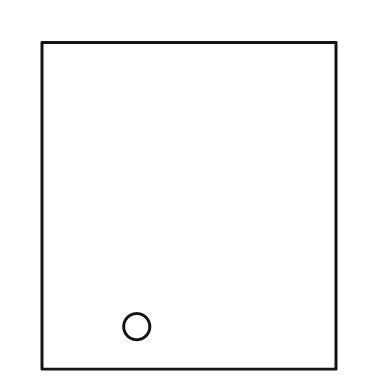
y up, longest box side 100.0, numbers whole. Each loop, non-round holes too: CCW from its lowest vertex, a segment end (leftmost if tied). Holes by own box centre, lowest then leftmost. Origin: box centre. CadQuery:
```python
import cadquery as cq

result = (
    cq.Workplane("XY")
    .moveTo(-45.0, -50.0)
    .lineTo(45.0, -50.0)
    .lineTo(45.0, 50.0)
    .lineTo(-45.0, 50.0)
    .close()
    .moveTo(-16.0, -37.0)
    .circle(4.0)
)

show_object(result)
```